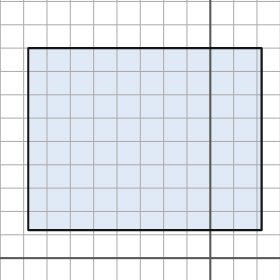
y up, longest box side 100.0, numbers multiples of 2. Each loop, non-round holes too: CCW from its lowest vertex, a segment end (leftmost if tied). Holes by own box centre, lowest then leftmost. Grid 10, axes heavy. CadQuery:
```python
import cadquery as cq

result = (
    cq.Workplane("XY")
    .moveTo(-78.0, 12.0)
    .lineTo(22.0, 12.0)
    .lineTo(22.0, 90.0)
    .lineTo(-78.0, 90.0)
    .close()
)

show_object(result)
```